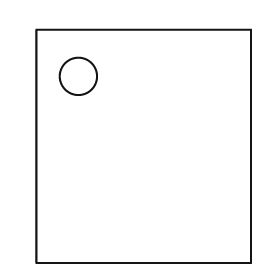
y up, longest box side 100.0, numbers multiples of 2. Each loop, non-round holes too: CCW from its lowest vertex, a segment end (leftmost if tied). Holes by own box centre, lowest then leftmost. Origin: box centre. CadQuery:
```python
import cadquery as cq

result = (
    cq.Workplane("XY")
    .moveTo(-46.0, -50.0)
    .lineTo(46.0, -50.0)
    .lineTo(46.0, 50.0)
    .lineTo(-46.0, 50.0)
    .close()
    .moveTo(-28.0, 30.0)
    .circle(8.0)
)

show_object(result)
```